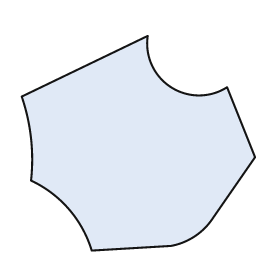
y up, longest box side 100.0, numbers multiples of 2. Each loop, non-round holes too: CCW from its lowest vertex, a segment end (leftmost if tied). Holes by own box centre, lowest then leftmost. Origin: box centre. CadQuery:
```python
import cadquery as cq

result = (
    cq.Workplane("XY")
    .moveTo(-20.0, -46.0)
    .lineTo(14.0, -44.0)
    .threePointArc((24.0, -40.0), (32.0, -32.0))
    .lineTo(50.0, -6.0)
    .lineTo(38.0, 24.0)
    .threePointArc((14.0, 24.0), (4.0, 46.0))
    .lineTo(-50.0, 20.0)
    .threePointArc((-46.0, 2.0), (-46.0, -16.0))
    .threePointArc((-30.0, -28.0), (-20.0, -46.0))
    .close()
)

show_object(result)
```